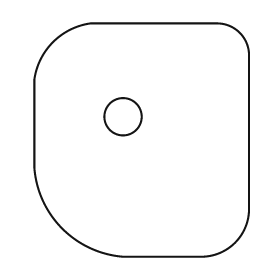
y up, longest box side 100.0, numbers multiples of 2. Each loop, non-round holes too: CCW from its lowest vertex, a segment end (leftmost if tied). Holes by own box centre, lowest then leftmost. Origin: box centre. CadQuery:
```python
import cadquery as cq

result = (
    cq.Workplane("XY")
    .moveTo(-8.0, -50.0)
    .lineTo(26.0, -50.0)
    .threePointArc((40.0, -44.0), (46.0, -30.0))
    .lineTo(46.0, 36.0)
    .threePointArc((42.0, 46.0), (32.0, 50.0))
    .lineTo(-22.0, 50.0)
    .threePointArc((-38.0, 42.0), (-46.0, 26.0))
    .lineTo(-46.0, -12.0)
    .threePointArc((-34.0, -38.0), (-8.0, -50.0))
    .close()
    .moveTo(-8.0, 10.0)
    .circle(8.0)
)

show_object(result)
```